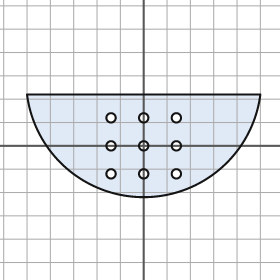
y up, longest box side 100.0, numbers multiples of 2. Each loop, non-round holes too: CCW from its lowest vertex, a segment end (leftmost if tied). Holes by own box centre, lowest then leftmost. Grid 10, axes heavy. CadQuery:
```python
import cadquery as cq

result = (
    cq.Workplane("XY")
    .moveTo(-50.0, 22.0)
    .threePointArc((0.0, -22.0), (50.0, 22.0))
    .close()
    .moveTo(-14.0, -12.0)
    .circle(2.0)
    .moveTo(0.0, -12.0)
    .circle(2.0)
    .moveTo(14.0, -12.0)
    .circle(2.0)
    .moveTo(-14.0, 0.0)
    .circle(2.0)
    .moveTo(0.0, 0.0)
    .circle(2.0)
    .moveTo(14.0, 0.0)
    .circle(2.0)
    .moveTo(-14.0, 12.0)
    .circle(2.0)
    .moveTo(0.0, 12.0)
    .circle(2.0)
    .moveTo(14.0, 12.0)
    .circle(2.0)
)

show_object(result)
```